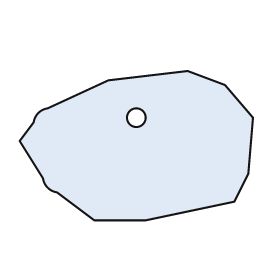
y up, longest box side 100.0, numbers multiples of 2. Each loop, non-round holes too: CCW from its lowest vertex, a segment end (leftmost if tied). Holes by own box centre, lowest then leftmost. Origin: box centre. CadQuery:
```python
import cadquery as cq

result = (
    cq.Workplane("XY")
    .moveTo(-18.0, -32.0)
    .lineTo(4.0, -32.0)
    .lineTo(42.0, -24.0)
    .lineTo(48.0, -12.0)
    .lineTo(50.0, 12.0)
    .lineTo(38.0, 26.0)
    .lineTo(22.0, 32.0)
    .lineTo(-12.0, 28.0)
    .lineTo(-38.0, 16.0)
    .threePointArc((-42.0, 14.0), (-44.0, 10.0))
    .lineTo(-50.0, 2.0)
    .lineTo(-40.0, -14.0)
    .threePointArc((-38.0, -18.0), (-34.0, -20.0))
    .close()
    .moveTo(0.0, 12.0)
    .circle(4.0)
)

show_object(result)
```